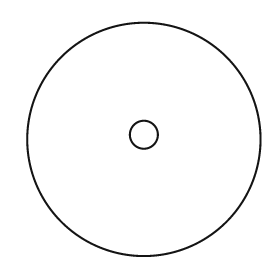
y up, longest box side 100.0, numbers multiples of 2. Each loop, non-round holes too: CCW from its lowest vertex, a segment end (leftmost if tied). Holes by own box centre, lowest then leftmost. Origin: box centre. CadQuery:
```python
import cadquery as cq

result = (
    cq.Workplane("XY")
    .moveTo(0.0, 0.0)
    .circle(50.0)
    .moveTo(0.0, 2.0)
    .circle(6.0)
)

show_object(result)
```